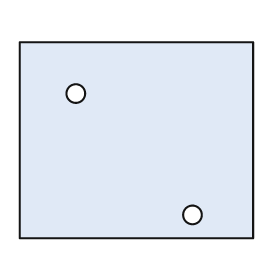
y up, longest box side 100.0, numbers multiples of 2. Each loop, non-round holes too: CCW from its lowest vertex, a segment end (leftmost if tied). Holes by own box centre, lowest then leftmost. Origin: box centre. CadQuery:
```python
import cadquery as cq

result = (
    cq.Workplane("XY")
    .moveTo(-50.0, -42.0)
    .lineTo(50.0, -42.0)
    .lineTo(50.0, 42.0)
    .lineTo(-50.0, 42.0)
    .close()
    .moveTo(24.0, -32.0)
    .circle(4.0)
    .moveTo(-26.0, 20.0)
    .circle(4.0)
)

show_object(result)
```